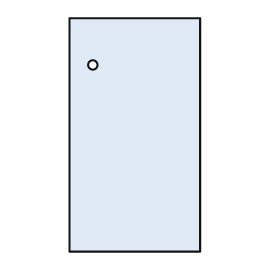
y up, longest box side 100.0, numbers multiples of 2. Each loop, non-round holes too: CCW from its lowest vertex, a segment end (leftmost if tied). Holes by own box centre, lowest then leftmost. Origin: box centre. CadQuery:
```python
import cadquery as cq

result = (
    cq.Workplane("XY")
    .moveTo(-28.0, -50.0)
    .lineTo(28.0, -50.0)
    .lineTo(28.0, 50.0)
    .lineTo(-28.0, 50.0)
    .close()
    .moveTo(-18.0, 30.0)
    .circle(2.0)
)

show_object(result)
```